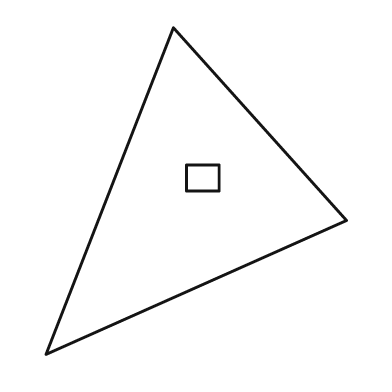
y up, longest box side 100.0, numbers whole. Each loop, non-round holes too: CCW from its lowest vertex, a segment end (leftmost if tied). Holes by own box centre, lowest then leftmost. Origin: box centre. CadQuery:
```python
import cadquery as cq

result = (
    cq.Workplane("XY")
    .moveTo(-46.0, -50.0)
    .lineTo(46.0, -9.0)
    .lineTo(-7.0, 50.0)
    .close()
    .moveTo(-3.0, 0.0)
    .lineTo(7.0, 0.0)
    .lineTo(7.0, 8.0)
    .lineTo(-3.0, 8.0)
    .close()
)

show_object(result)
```